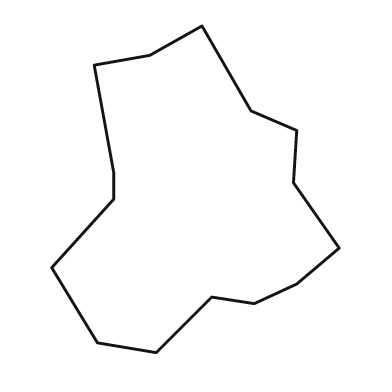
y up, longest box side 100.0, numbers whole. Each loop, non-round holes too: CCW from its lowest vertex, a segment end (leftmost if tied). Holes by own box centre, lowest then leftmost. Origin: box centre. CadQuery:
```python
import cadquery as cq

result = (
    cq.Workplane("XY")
    .moveTo(-12.0, -50.0)
    .lineTo(5.0, -33.0)
    .lineTo(18.0, -35.0)
    .lineTo(31.0, -29.0)
    .lineTo(44.0, -18.0)
    .lineTo(30.0, 2.0)
    .lineTo(31.0, 18.0)
    .lineTo(17.0, 24.0)
    .lineTo(2.0, 50.0)
    .lineTo(-14.0, 41.0)
    .lineTo(-31.0, 38.0)
    .lineTo(-25.0, 5.0)
    .lineTo(-25.0, -3.0)
    .lineTo(-44.0, -24.0)
    .lineTo(-30.0, -47.0)
    .close()
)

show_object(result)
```